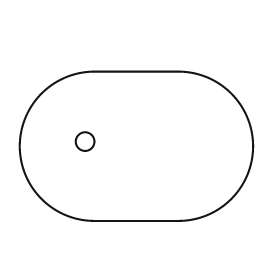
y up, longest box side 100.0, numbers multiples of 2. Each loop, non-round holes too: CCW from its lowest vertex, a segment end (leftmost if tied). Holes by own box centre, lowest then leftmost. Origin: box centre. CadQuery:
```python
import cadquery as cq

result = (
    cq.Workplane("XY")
    .moveTo(-18.0, -32.0)
    .lineTo(18.0, -32.0)
    .threePointArc((50.0, 0.0), (18.0, 32.0))
    .lineTo(-18.0, 32.0)
    .threePointArc((-50.0, 0.0), (-18.0, -32.0))
    .close()
    .moveTo(-22.0, 2.0)
    .circle(4.0)
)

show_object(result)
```